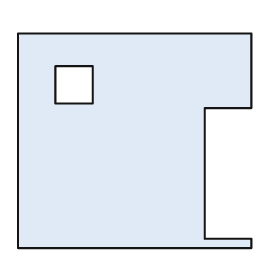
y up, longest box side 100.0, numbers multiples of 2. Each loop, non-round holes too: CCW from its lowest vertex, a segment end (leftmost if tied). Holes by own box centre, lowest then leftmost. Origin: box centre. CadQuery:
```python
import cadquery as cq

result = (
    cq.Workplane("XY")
    .moveTo(-50.0, -46.0)
    .lineTo(50.0, -46.0)
    .lineTo(50.0, -42.0)
    .lineTo(30.0, -42.0)
    .lineTo(30.0, 14.0)
    .lineTo(50.0, 14.0)
    .lineTo(50.0, 46.0)
    .lineTo(-50.0, 46.0)
    .close()
    .moveTo(-34.0, 16.0)
    .lineTo(-18.0, 16.0)
    .lineTo(-18.0, 32.0)
    .lineTo(-34.0, 32.0)
    .close()
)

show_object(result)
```